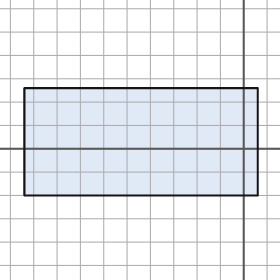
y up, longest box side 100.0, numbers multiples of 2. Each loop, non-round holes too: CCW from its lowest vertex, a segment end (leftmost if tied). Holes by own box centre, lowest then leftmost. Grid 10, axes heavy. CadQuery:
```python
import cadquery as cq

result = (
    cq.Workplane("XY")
    .moveTo(-94.0, -20.0)
    .lineTo(6.0, -20.0)
    .lineTo(6.0, 26.0)
    .lineTo(-94.0, 26.0)
    .close()
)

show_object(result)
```